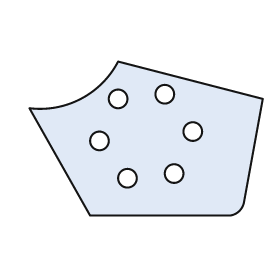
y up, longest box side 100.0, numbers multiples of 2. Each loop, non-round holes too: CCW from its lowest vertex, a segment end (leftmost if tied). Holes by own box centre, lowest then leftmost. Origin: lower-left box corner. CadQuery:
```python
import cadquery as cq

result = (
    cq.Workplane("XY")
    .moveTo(26.0, 0.0)
    .lineTo(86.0, 0.0)
    .threePointArc((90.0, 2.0), (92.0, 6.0))
    .lineTo(100.0, 50.0)
    .lineTo(38.0, 66.0)
    .threePointArc((22.0, 50.0), (0.0, 46.0))
    .close()
    .moveTo(42.0, 16.0)
    .circle(4.0)
    .moveTo(62.0, 18.0)
    .circle(4.0)
    .moveTo(30.0, 32.0)
    .circle(4.0)
    .moveTo(70.0, 36.0)
    .circle(4.0)
    .moveTo(38.0, 50.0)
    .circle(4.0)
    .moveTo(58.0, 52.0)
    .circle(4.0)
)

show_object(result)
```